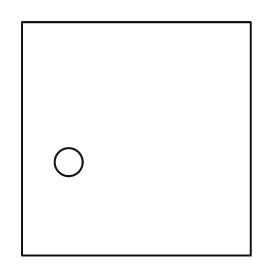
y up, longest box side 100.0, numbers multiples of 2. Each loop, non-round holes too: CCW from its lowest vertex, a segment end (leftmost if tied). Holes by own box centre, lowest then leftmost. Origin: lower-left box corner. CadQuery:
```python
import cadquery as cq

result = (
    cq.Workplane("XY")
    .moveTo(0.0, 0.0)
    .lineTo(98.0, 0.0)
    .lineTo(98.0, 100.0)
    .lineTo(0.0, 100.0)
    .close()
    .moveTo(20.0, 40.0)
    .circle(6.0)
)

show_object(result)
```